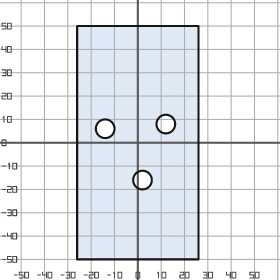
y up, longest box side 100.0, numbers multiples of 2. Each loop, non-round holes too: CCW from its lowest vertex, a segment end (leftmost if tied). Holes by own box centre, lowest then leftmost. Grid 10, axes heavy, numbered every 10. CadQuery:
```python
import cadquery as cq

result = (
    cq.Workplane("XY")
    .moveTo(-26.0, -50.0)
    .lineTo(26.0, -50.0)
    .lineTo(26.0, 50.0)
    .lineTo(-26.0, 50.0)
    .close()
    .moveTo(2.0, -16.0)
    .circle(4.0)
    .moveTo(-14.0, 6.0)
    .circle(4.0)
    .moveTo(12.0, 8.0)
    .circle(4.0)
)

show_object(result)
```